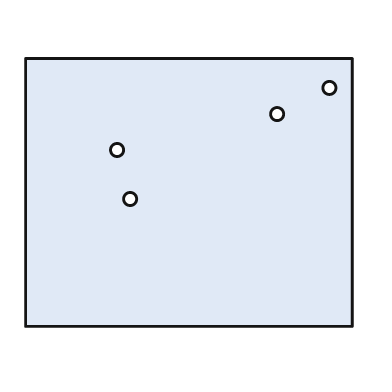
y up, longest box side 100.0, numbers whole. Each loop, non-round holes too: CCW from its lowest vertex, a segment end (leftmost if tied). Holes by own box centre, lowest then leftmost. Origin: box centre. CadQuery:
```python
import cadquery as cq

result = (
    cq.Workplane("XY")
    .moveTo(-50.0, -41.0)
    .lineTo(50.0, -41.0)
    .lineTo(50.0, 41.0)
    .lineTo(-50.0, 41.0)
    .close()
    .moveTo(-18.0, -2.0)
    .circle(2.0)
    .moveTo(-22.0, 13.0)
    .circle(2.0)
    .moveTo(27.0, 24.0)
    .circle(2.0)
    .moveTo(43.0, 32.0)
    .circle(2.0)
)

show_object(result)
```